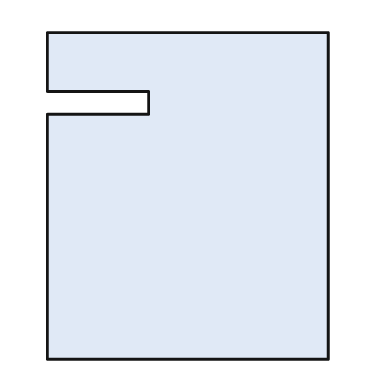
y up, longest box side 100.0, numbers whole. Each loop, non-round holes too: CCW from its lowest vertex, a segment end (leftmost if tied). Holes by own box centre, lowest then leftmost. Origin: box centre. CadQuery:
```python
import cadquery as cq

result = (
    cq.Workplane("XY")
    .moveTo(-43.0, -50.0)
    .lineTo(43.0, -50.0)
    .lineTo(43.0, 50.0)
    .lineTo(-43.0, 50.0)
    .lineTo(-43.0, 32.0)
    .lineTo(-12.0, 32.0)
    .lineTo(-12.0, 25.0)
    .lineTo(-43.0, 25.0)
    .close()
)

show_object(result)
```